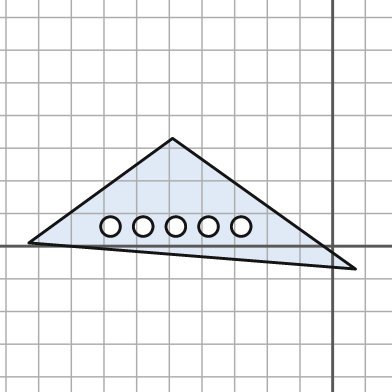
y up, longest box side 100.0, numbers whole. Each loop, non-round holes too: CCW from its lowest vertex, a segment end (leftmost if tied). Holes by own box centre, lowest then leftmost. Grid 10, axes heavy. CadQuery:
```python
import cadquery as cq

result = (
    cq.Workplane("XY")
    .moveTo(7.0, -7.0)
    .lineTo(-49.0, 33.0)
    .lineTo(-93.0, 1.0)
    .close()
    .moveTo(-68.0, 6.0)
    .circle(3.0)
    .moveTo(-58.0, 6.0)
    .circle(3.0)
    .moveTo(-48.0, 6.0)
    .circle(3.0)
    .moveTo(-38.0, 6.0)
    .circle(3.0)
    .moveTo(-28.0, 6.0)
    .circle(3.0)
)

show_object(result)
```